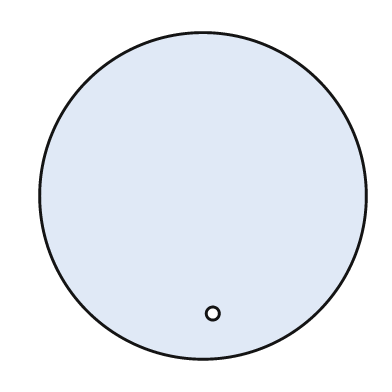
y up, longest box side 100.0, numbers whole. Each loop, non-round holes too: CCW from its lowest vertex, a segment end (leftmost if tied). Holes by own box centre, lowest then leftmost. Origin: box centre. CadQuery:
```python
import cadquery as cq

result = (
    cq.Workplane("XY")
    .moveTo(0.0, 0.0)
    .circle(50.0)
    .moveTo(3.0, -36.0)
    .circle(2.0)
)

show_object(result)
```